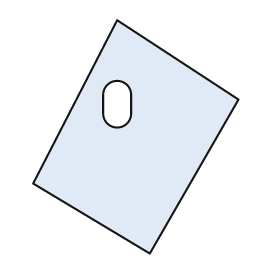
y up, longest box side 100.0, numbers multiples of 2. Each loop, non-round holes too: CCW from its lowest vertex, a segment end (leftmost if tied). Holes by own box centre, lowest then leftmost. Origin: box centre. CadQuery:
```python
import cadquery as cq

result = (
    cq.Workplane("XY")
    .moveTo(6.0, -50.0)
    .lineTo(44.0, 16.0)
    .lineTo(-8.0, 50.0)
    .lineTo(-44.0, -20.0)
    .close()
    .moveTo(-14.0, 10.0)
    .threePointArc((-8.0, 4.0), (-2.0, 10.0))
    .lineTo(-2.0, 18.0)
    .threePointArc((-8.0, 24.0), (-14.0, 18.0))
    .close()
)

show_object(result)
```